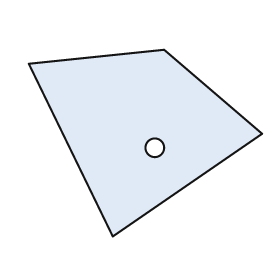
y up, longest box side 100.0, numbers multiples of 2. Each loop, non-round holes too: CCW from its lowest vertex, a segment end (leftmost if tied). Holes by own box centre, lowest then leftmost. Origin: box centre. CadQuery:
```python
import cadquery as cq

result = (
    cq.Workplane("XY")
    .moveTo(-14.0, -40.0)
    .lineTo(50.0, 4.0)
    .lineTo(8.0, 40.0)
    .lineTo(-50.0, 34.0)
    .close()
    .moveTo(4.0, -2.0)
    .circle(4.0)
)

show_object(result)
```